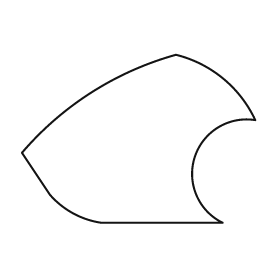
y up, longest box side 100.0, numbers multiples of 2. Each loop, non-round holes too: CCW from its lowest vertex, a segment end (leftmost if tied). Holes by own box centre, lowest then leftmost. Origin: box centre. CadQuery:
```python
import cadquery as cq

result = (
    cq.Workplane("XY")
    .moveTo(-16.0, -36.0)
    .lineTo(36.0, -36.0)
    .threePointArc((24.0, -8.0), (50.0, 8.0))
    .threePointArc((36.0, 26.0), (16.0, 36.0))
    .threePointArc((-20.0, 20.0), (-50.0, -6.0))
    .lineTo(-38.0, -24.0)
    .threePointArc((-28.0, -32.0), (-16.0, -36.0))
    .close()
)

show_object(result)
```